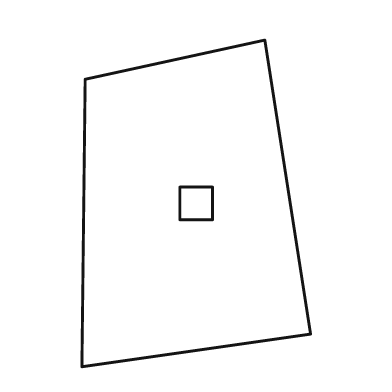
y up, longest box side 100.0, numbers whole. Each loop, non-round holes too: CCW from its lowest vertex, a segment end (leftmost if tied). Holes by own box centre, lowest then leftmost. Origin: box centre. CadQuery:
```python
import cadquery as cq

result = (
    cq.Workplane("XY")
    .moveTo(-35.0, -50.0)
    .lineTo(35.0, -40.0)
    .lineTo(21.0, 50.0)
    .lineTo(-34.0, 38.0)
    .close()
    .moveTo(-5.0, -5.0)
    .lineTo(5.0, -5.0)
    .lineTo(5.0, 5.0)
    .lineTo(-5.0, 5.0)
    .close()
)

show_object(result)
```